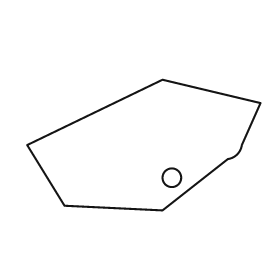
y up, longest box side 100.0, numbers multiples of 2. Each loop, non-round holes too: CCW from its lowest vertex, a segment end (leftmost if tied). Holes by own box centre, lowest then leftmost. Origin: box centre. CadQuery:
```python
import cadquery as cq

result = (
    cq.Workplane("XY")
    .moveTo(8.0, -28.0)
    .lineTo(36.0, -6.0)
    .threePointArc((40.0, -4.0), (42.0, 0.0))
    .lineTo(50.0, 18.0)
    .lineTo(8.0, 28.0)
    .lineTo(-50.0, 0.0)
    .lineTo(-34.0, -26.0)
    .close()
    .moveTo(12.0, -14.0)
    .circle(4.0)
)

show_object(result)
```